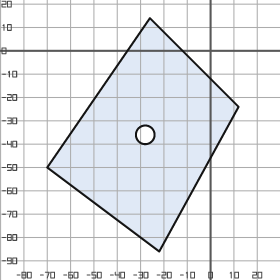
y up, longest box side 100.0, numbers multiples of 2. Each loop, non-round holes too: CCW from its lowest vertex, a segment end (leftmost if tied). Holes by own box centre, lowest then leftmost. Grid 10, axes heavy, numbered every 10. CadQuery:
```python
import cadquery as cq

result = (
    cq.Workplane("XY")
    .moveTo(-22.0, -86.0)
    .lineTo(12.0, -24.0)
    .lineTo(-26.0, 14.0)
    .lineTo(-70.0, -50.0)
    .close()
    .moveTo(-28.0, -36.0)
    .circle(4.0)
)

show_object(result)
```